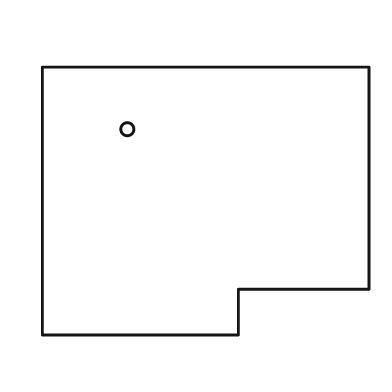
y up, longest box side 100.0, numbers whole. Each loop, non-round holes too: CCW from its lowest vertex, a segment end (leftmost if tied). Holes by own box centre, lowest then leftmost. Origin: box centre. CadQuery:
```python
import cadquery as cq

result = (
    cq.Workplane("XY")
    .moveTo(-50.0, -41.0)
    .lineTo(10.0, -41.0)
    .lineTo(10.0, -27.0)
    .lineTo(50.0, -27.0)
    .lineTo(50.0, 41.0)
    .lineTo(-50.0, 41.0)
    .close()
    .moveTo(-24.0, 22.0)
    .circle(2.0)
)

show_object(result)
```